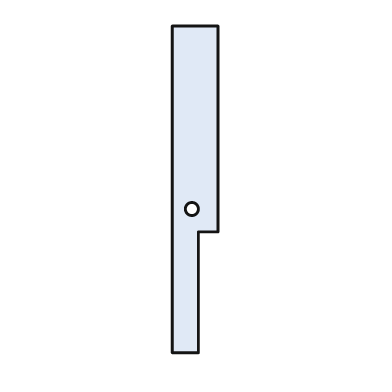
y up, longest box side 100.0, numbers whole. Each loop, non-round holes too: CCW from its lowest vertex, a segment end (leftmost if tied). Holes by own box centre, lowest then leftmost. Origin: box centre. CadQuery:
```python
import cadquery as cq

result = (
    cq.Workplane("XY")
    .moveTo(-7.0, -50.0)
    .lineTo(1.0, -50.0)
    .lineTo(1.0, -13.0)
    .lineTo(7.0, -13.0)
    .lineTo(7.0, 50.0)
    .lineTo(-7.0, 50.0)
    .close()
    .moveTo(-1.0, -6.0)
    .circle(2.0)
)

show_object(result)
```